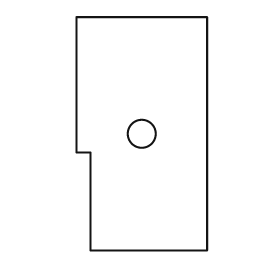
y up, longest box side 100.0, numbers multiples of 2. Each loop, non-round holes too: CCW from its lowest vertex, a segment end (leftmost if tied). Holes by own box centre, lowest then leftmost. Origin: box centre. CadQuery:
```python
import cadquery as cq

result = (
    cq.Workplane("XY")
    .moveTo(-22.0, -50.0)
    .lineTo(28.0, -50.0)
    .lineTo(28.0, 50.0)
    .lineTo(-28.0, 50.0)
    .lineTo(-28.0, -8.0)
    .lineTo(-22.0, -8.0)
    .close()
    .moveTo(0.0, 0.0)
    .circle(6.0)
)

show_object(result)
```